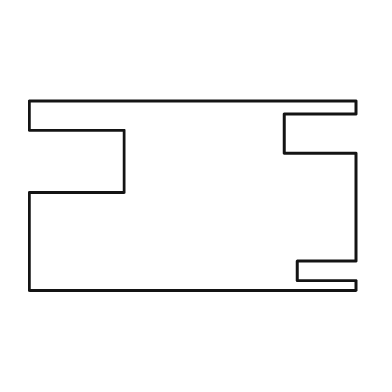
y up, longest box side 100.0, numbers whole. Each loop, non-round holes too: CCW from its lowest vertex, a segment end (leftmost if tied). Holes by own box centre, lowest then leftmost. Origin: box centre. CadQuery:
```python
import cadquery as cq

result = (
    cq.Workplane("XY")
    .moveTo(-50.0, -29.0)
    .lineTo(50.0, -29.0)
    .lineTo(50.0, -26.0)
    .lineTo(32.0, -26.0)
    .lineTo(32.0, -20.0)
    .lineTo(50.0, -20.0)
    .lineTo(50.0, 13.0)
    .lineTo(28.0, 13.0)
    .lineTo(28.0, 25.0)
    .lineTo(50.0, 25.0)
    .lineTo(50.0, 29.0)
    .lineTo(-50.0, 29.0)
    .lineTo(-50.0, 20.0)
    .lineTo(-21.0, 20.0)
    .lineTo(-21.0, 1.0)
    .lineTo(-50.0, 1.0)
    .close()
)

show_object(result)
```